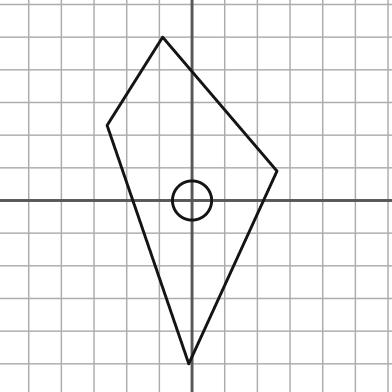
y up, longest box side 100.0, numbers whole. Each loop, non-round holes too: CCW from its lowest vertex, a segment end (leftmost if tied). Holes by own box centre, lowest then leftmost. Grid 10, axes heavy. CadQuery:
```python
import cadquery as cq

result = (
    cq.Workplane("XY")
    .moveTo(-1.0, -50.0)
    .lineTo(26.0, 9.0)
    .lineTo(-9.0, 50.0)
    .lineTo(-26.0, 23.0)
    .close()
    .moveTo(0.0, 0.0)
    .circle(6.0)
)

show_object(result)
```